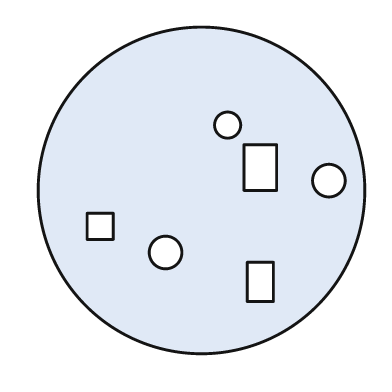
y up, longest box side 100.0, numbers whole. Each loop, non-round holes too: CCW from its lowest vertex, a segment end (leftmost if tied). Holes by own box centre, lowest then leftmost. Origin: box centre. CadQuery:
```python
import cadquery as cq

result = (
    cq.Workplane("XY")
    .moveTo(0.0, 0.0)
    .circle(50.0)
    .moveTo(14.0, -34.0)
    .lineTo(22.0, -34.0)
    .lineTo(22.0, -22.0)
    .lineTo(14.0, -22.0)
    .close()
    .moveTo(-11.0, -19.0)
    .circle(5.0)
    .moveTo(-35.0, -15.0)
    .lineTo(-27.0, -15.0)
    .lineTo(-27.0, -7.0)
    .lineTo(-35.0, -7.0)
    .close()
    .moveTo(39.0, 3.0)
    .circle(5.0)
    .moveTo(13.0, 0.0)
    .lineTo(23.0, 0.0)
    .lineTo(23.0, 14.0)
    .lineTo(13.0, 14.0)
    .close()
    .moveTo(8.0, 20.0)
    .circle(4.0)
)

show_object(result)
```